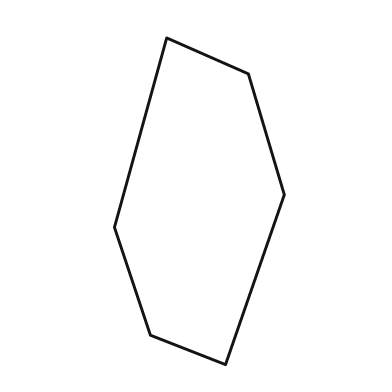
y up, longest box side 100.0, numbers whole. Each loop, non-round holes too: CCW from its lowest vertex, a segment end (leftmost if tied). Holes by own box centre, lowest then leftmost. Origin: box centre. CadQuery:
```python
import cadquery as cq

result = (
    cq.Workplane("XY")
    .moveTo(8.0, -50.0)
    .lineTo(26.0, 2.0)
    .lineTo(15.0, 39.0)
    .lineTo(-10.0, 50.0)
    .lineTo(-26.0, -8.0)
    .lineTo(-15.0, -41.0)
    .close()
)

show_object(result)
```